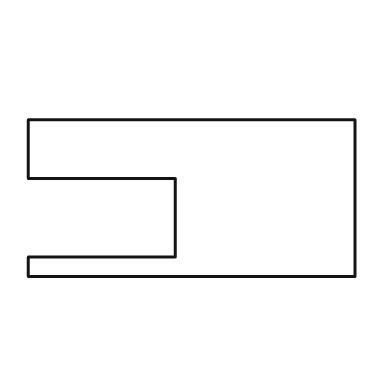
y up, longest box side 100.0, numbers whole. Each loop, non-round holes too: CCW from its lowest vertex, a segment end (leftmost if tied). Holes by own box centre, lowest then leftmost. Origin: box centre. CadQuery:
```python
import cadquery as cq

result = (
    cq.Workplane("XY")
    .moveTo(-50.0, -24.0)
    .lineTo(50.0, -24.0)
    .lineTo(50.0, 24.0)
    .lineTo(-50.0, 24.0)
    .lineTo(-50.0, 6.0)
    .lineTo(-5.0, 6.0)
    .lineTo(-5.0, -18.0)
    .lineTo(-50.0, -18.0)
    .close()
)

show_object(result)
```